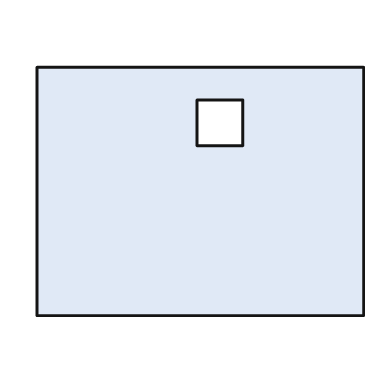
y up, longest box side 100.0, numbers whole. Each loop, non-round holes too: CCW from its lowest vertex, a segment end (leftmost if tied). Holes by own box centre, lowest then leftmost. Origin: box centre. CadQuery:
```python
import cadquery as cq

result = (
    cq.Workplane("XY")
    .moveTo(-50.0, -38.0)
    .lineTo(50.0, -38.0)
    .lineTo(50.0, 38.0)
    .lineTo(-50.0, 38.0)
    .close()
    .moveTo(-1.0, 14.0)
    .lineTo(13.0, 14.0)
    .lineTo(13.0, 28.0)
    .lineTo(-1.0, 28.0)
    .close()
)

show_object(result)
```